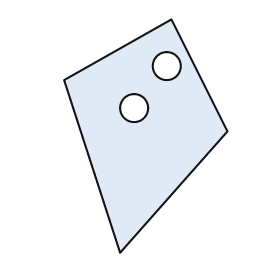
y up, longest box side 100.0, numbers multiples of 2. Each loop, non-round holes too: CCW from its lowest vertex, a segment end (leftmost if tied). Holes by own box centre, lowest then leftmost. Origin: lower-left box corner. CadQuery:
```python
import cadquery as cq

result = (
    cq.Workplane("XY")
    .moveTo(24.0, 0.0)
    .lineTo(70.0, 52.0)
    .lineTo(46.0, 100.0)
    .lineTo(0.0, 74.0)
    .close()
    .moveTo(30.0, 62.0)
    .circle(6.0)
    .moveTo(44.0, 80.0)
    .circle(6.0)
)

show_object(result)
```